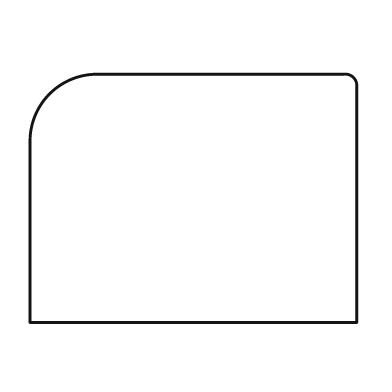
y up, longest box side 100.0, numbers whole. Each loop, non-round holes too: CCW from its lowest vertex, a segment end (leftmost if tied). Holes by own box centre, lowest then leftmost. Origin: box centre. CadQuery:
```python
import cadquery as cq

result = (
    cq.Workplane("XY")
    .moveTo(-50.0, -38.0)
    .lineTo(50.0, -38.0)
    .lineTo(50.0, 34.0)
    .threePointArc((49.0, 37.0), (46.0, 38.0))
    .lineTo(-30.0, 38.0)
    .threePointArc((-44.0, 32.0), (-50.0, 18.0))
    .close()
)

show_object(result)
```